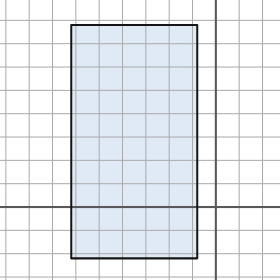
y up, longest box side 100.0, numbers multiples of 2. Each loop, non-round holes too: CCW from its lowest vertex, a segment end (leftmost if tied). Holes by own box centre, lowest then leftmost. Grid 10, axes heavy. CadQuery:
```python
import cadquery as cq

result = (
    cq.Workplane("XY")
    .moveTo(-62.0, -22.0)
    .lineTo(-8.0, -22.0)
    .lineTo(-8.0, 78.0)
    .lineTo(-62.0, 78.0)
    .close()
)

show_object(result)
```